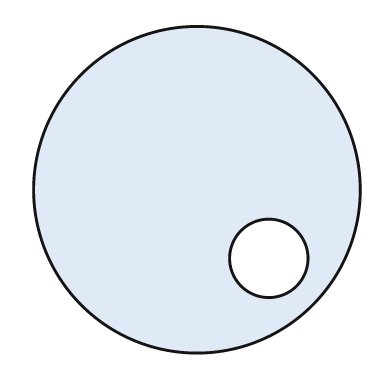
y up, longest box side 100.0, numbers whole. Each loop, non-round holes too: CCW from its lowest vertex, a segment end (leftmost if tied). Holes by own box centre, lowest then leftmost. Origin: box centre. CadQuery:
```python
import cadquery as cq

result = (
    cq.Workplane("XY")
    .moveTo(0.0, 0.0)
    .circle(50.0)
    .moveTo(22.0, -21.0)
    .circle(12.0)
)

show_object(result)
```